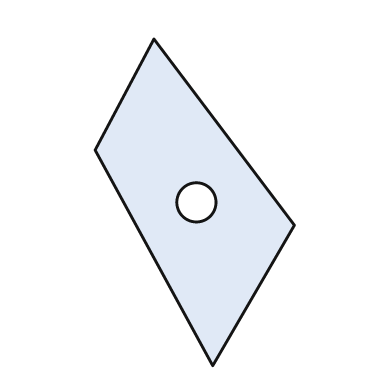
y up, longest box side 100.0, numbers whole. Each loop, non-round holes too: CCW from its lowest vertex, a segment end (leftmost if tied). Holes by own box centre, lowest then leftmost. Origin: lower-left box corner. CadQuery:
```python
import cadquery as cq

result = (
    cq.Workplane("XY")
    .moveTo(36.0, 0.0)
    .lineTo(61.0, 43.0)
    .lineTo(18.0, 100.0)
    .lineTo(0.0, 66.0)
    .close()
    .moveTo(31.0, 50.0)
    .circle(6.0)
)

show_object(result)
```